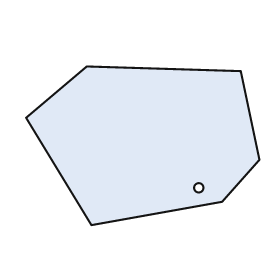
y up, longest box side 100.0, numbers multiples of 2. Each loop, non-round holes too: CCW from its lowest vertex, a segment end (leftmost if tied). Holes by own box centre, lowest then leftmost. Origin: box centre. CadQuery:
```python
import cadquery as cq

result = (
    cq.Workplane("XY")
    .moveTo(-22.0, -34.0)
    .lineTo(34.0, -24.0)
    .lineTo(50.0, -6.0)
    .lineTo(42.0, 32.0)
    .lineTo(-24.0, 34.0)
    .lineTo(-50.0, 12.0)
    .close()
    .moveTo(24.0, -18.0)
    .circle(2.0)
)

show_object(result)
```